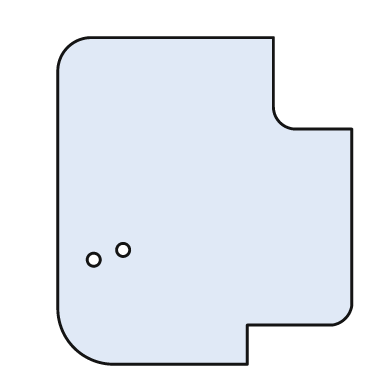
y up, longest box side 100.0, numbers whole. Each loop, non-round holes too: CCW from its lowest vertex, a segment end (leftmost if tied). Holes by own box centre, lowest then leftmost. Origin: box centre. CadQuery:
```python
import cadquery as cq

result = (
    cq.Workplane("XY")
    .moveTo(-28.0, -50.0)
    .lineTo(13.0, -50.0)
    .lineTo(13.0, -38.0)
    .lineTo(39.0, -38.0)
    .threePointArc((43.0, -36.0), (45.0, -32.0))
    .lineTo(45.0, 22.0)
    .lineTo(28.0, 22.0)
    .threePointArc((23.0, 24.0), (21.0, 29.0))
    .lineTo(21.0, 50.0)
    .lineTo(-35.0, 50.0)
    .threePointArc((-42.0, 47.0), (-45.0, 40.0))
    .lineTo(-45.0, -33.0)
    .threePointArc((-40.0, -45.0), (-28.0, -50.0))
    .close()
    .moveTo(-34.0, -18.0)
    .circle(2.0)
    .moveTo(-25.0, -15.0)
    .circle(2.0)
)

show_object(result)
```